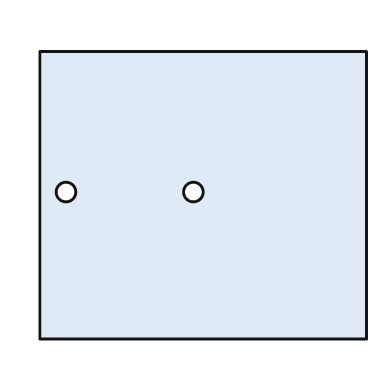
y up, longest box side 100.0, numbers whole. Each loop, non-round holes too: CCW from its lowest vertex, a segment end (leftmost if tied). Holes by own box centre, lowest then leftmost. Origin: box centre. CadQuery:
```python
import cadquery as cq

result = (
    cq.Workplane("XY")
    .moveTo(-50.0, -44.0)
    .lineTo(50.0, -44.0)
    .lineTo(50.0, 44.0)
    .lineTo(-50.0, 44.0)
    .close()
    .moveTo(-42.0, 1.0)
    .circle(3.0)
    .moveTo(-3.0, 1.0)
    .circle(3.0)
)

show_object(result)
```